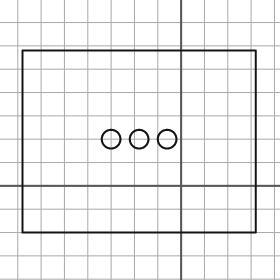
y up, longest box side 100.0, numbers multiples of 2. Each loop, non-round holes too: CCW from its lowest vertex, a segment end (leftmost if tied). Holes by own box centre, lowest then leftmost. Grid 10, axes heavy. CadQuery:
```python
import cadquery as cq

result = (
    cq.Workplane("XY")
    .moveTo(-68.0, -20.0)
    .lineTo(32.0, -20.0)
    .lineTo(32.0, 58.0)
    .lineTo(-68.0, 58.0)
    .close()
    .moveTo(-30.0, 20.0)
    .circle(4.0)
    .moveTo(-18.0, 20.0)
    .circle(4.0)
    .moveTo(-6.0, 20.0)
    .circle(4.0)
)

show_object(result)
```